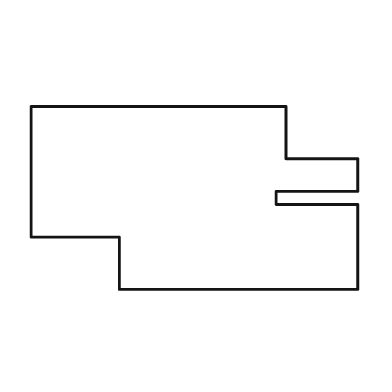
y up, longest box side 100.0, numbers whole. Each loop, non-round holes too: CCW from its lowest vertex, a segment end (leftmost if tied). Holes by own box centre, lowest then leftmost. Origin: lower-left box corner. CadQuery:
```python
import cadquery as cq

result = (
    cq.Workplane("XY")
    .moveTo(27.0, 0.0)
    .lineTo(100.0, 0.0)
    .lineTo(100.0, 26.0)
    .lineTo(75.0, 26.0)
    .lineTo(75.0, 30.0)
    .lineTo(100.0, 30.0)
    .lineTo(100.0, 40.0)
    .lineTo(78.0, 40.0)
    .lineTo(78.0, 56.0)
    .lineTo(0.0, 56.0)
    .lineTo(0.0, 16.0)
    .lineTo(27.0, 16.0)
    .close()
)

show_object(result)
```